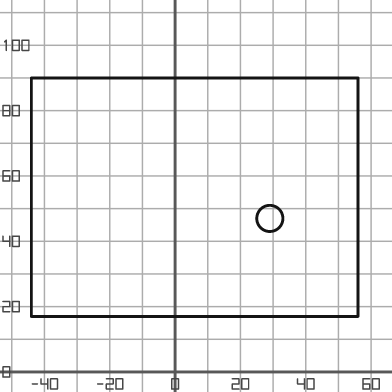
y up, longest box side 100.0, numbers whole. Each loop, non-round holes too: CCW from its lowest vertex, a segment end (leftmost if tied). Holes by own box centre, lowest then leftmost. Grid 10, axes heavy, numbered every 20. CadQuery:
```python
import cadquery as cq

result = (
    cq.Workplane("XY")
    .moveTo(-44.0, 17.0)
    .lineTo(56.0, 17.0)
    .lineTo(56.0, 90.0)
    .lineTo(-44.0, 90.0)
    .close()
    .moveTo(29.0, 47.0)
    .circle(4.0)
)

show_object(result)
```